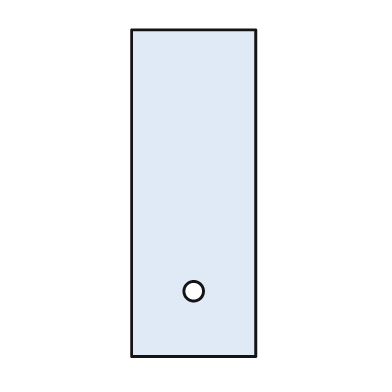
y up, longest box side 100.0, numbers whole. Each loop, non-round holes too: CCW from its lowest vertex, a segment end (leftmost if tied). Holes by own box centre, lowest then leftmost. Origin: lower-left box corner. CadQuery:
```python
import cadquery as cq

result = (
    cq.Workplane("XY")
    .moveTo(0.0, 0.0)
    .lineTo(38.0, 0.0)
    .lineTo(38.0, 100.0)
    .lineTo(0.0, 100.0)
    .close()
    .moveTo(19.0, 20.0)
    .circle(3.0)
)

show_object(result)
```